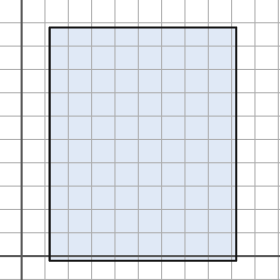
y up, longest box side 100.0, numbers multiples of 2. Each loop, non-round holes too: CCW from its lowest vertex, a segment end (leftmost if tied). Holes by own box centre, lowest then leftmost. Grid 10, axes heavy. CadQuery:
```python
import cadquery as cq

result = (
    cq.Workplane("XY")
    .moveTo(12.0, -2.0)
    .lineTo(92.0, -2.0)
    .lineTo(92.0, 98.0)
    .lineTo(12.0, 98.0)
    .close()
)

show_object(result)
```